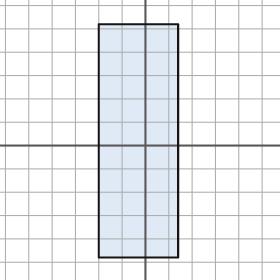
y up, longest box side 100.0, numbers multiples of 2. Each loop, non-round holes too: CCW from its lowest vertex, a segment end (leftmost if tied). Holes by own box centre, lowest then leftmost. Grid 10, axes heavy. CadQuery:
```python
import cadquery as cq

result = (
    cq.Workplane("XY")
    .moveTo(-20.0, -48.0)
    .lineTo(14.0, -48.0)
    .lineTo(14.0, 52.0)
    .lineTo(-20.0, 52.0)
    .close()
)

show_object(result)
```